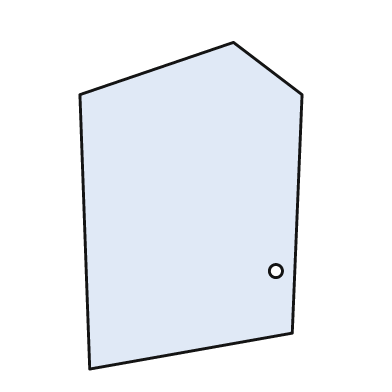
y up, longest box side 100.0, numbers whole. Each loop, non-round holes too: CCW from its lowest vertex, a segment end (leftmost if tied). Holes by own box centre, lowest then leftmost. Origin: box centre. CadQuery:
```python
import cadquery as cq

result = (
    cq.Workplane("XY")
    .moveTo(-31.0, -50.0)
    .lineTo(31.0, -39.0)
    .lineTo(34.0, 34.0)
    .lineTo(13.0, 50.0)
    .lineTo(-34.0, 34.0)
    .close()
    .moveTo(26.0, -20.0)
    .circle(2.0)
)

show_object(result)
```